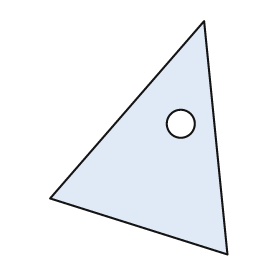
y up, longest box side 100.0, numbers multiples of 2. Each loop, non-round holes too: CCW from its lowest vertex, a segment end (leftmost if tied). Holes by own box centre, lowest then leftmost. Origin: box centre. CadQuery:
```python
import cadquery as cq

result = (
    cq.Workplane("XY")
    .moveTo(38.0, -50.0)
    .lineTo(28.0, 50.0)
    .lineTo(-38.0, -26.0)
    .close()
    .moveTo(18.0, 6.0)
    .circle(6.0)
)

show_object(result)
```